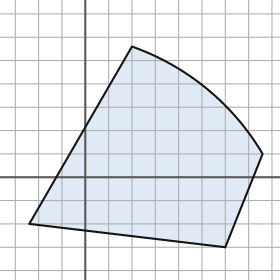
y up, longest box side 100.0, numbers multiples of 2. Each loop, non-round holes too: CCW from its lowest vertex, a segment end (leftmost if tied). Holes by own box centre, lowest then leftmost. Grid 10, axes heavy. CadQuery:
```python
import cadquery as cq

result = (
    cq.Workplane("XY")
    .moveTo(60.0, -30.0)
    .lineTo(76.0, 10.0)
    .threePointArc((52.0, 38.0), (20.0, 56.0))
    .lineTo(-24.0, -20.0)
    .close()
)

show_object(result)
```